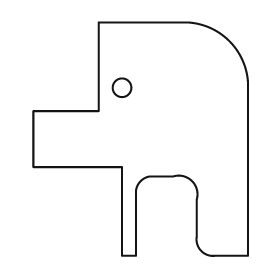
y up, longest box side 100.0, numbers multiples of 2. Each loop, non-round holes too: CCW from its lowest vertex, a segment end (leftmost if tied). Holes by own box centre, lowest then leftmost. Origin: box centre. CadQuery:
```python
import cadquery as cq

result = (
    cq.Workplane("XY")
    .moveTo(-8.0, -50.0)
    .lineTo(-2.0, -50.0)
    .lineTo(-2.0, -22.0)
    .threePointArc((0.0, -18.0), (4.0, -16.0))
    .lineTo(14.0, -16.0)
    .threePointArc((22.0, -18.0), (24.0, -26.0))
    .lineTo(24.0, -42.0)
    .threePointArc((26.0, -48.0), (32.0, -50.0))
    .lineTo(46.0, -50.0)
    .lineTo(46.0, 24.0)
    .threePointArc((38.0, 42.0), (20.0, 50.0))
    .lineTo(-18.0, 50.0)
    .lineTo(-18.0, 12.0)
    .lineTo(-46.0, 12.0)
    .lineTo(-46.0, -12.0)
    .lineTo(-8.0, -12.0)
    .close()
    .moveTo(-8.0, 22.0)
    .circle(4.0)
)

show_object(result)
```